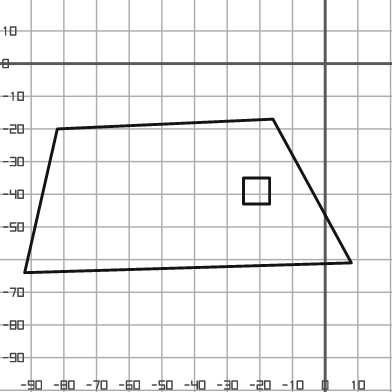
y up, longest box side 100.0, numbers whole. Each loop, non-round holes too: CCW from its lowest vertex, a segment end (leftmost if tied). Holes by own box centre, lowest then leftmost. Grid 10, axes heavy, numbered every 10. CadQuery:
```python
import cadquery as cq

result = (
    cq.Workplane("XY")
    .moveTo(-92.0, -64.0)
    .lineTo(8.0, -61.0)
    .lineTo(-16.0, -17.0)
    .lineTo(-82.0, -20.0)
    .close()
    .moveTo(-25.0, -43.0)
    .lineTo(-17.0, -43.0)
    .lineTo(-17.0, -35.0)
    .lineTo(-25.0, -35.0)
    .close()
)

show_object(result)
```